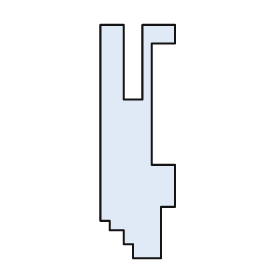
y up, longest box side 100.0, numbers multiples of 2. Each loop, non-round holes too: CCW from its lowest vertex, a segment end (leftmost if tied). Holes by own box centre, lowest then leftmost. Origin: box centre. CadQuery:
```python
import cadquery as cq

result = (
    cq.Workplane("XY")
    .moveTo(-2.0, -50.0)
    .lineTo(10.0, -50.0)
    .lineTo(10.0, -28.0)
    .lineTo(16.0, -28.0)
    .lineTo(16.0, -10.0)
    .lineTo(6.0, -10.0)
    .lineTo(6.0, 42.0)
    .lineTo(16.0, 42.0)
    .lineTo(16.0, 50.0)
    .lineTo(2.0, 50.0)
    .lineTo(2.0, 18.0)
    .lineTo(-6.0, 18.0)
    .lineTo(-6.0, 50.0)
    .lineTo(-16.0, 50.0)
    .lineTo(-16.0, -34.0)
    .lineTo(-12.0, -34.0)
    .lineTo(-12.0, -38.0)
    .lineTo(-6.0, -38.0)
    .lineTo(-6.0, -44.0)
    .lineTo(-2.0, -44.0)
    .close()
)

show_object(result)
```